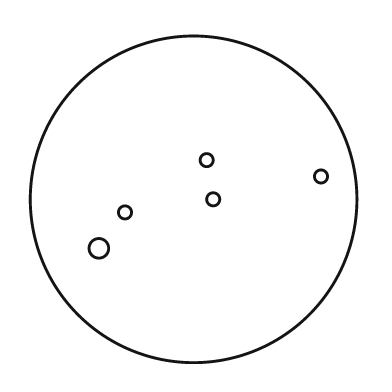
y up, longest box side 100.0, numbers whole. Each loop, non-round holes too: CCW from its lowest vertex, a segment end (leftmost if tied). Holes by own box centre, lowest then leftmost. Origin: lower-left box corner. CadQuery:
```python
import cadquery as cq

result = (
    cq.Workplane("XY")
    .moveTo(50.0, 50.0)
    .circle(50.0)
    .moveTo(21.0, 35.0)
    .circle(3.0)
    .moveTo(29.0, 46.0)
    .circle(2.0)
    .moveTo(56.0, 50.0)
    .circle(2.0)
    .moveTo(89.0, 57.0)
    .circle(2.0)
    .moveTo(54.0, 62.0)
    .circle(2.0)
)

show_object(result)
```